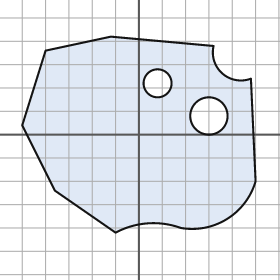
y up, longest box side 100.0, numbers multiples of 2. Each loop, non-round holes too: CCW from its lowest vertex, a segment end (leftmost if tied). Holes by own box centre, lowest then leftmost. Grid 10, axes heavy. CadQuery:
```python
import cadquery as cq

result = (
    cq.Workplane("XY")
    .moveTo(-10.0, -42.0)
    .threePointArc((4.0, -38.0), (18.0, -40.0))
    .threePointArc((38.0, -36.0), (50.0, -20.0))
    .lineTo(48.0, 24.0)
    .threePointArc((36.0, 26.0), (32.0, 38.0))
    .lineTo(-12.0, 42.0)
    .lineTo(-40.0, 36.0)
    .lineTo(-50.0, 4.0)
    .lineTo(-36.0, -24.0)
    .close()
    .moveTo(30.0, 8.0)
    .circle(8.0)
    .moveTo(8.0, 22.0)
    .circle(6.0)
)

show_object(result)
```